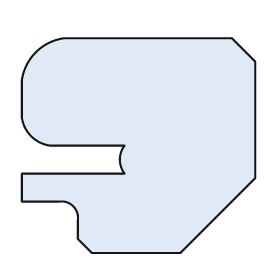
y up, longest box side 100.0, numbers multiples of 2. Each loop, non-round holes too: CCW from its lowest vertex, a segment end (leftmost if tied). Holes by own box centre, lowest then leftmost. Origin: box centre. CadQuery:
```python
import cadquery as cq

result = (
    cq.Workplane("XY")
    .moveTo(-20.0, -46.0)
    .lineTo(18.0, -46.0)
    .lineTo(50.0, -14.0)
    .lineTo(50.0, 36.0)
    .lineTo(40.0, 46.0)
    .lineTo(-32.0, 46.0)
    .threePointArc((-44.0, 40.0), (-50.0, 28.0))
    .lineTo(-50.0, 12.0)
    .threePointArc((-46.0, 4.0), (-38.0, 0.0))
    .lineTo(-6.0, 0.0)
    .threePointArc((-8.0, -6.0), (-6.0, -12.0))
    .lineTo(-50.0, -12.0)
    .lineTo(-50.0, -24.0)
    .lineTo(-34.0, -24.0)
    .threePointArc((-28.0, -26.0), (-26.0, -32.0))
    .lineTo(-26.0, -40.0)
    .close()
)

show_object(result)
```